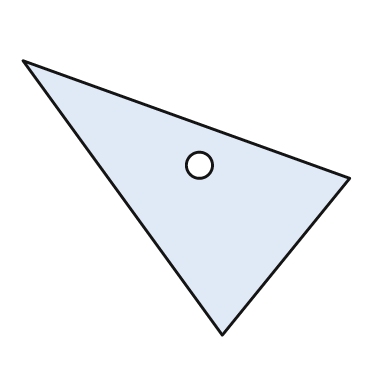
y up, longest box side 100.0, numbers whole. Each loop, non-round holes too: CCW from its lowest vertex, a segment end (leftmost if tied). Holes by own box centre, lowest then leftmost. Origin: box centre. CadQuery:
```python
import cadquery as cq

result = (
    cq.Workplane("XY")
    .moveTo(11.0, -42.0)
    .lineTo(50.0, 6.0)
    .lineTo(-50.0, 42.0)
    .close()
    .moveTo(4.0, 10.0)
    .circle(4.0)
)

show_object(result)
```